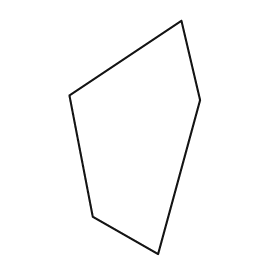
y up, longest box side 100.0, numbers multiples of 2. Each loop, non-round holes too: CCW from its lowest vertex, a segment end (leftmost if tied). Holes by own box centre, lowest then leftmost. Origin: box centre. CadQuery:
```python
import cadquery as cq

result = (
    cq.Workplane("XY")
    .moveTo(10.0, -50.0)
    .lineTo(28.0, 16.0)
    .lineTo(20.0, 50.0)
    .lineTo(-28.0, 18.0)
    .lineTo(-18.0, -34.0)
    .close()
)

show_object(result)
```